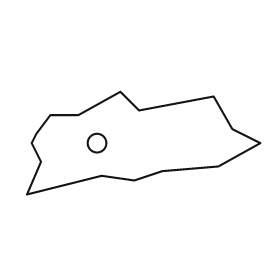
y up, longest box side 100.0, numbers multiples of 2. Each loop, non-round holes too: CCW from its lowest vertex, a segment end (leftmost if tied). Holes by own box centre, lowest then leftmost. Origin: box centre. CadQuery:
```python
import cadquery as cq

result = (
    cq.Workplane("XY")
    .moveTo(-50.0, -22.0)
    .lineTo(-18.0, -14.0)
    .lineTo(-4.0, -16.0)
    .lineTo(8.0, -12.0)
    .lineTo(32.0, -10.0)
    .lineTo(50.0, 0.0)
    .lineTo(38.0, 6.0)
    .lineTo(30.0, 20.0)
    .lineTo(-2.0, 14.0)
    .lineTo(-10.0, 22.0)
    .lineTo(-28.0, 12.0)
    .lineTo(-40.0, 12.0)
    .lineTo(-46.0, 4.0)
    .lineTo(-48.0, 0.0)
    .lineTo(-44.0, -8.0)
    .close()
    .moveTo(-20.0, 0.0)
    .circle(4.0)
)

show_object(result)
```